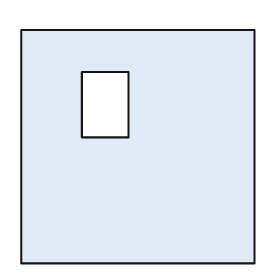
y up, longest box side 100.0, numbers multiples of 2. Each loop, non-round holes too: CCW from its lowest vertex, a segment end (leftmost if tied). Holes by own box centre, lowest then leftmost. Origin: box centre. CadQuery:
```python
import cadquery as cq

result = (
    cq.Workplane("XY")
    .moveTo(-50.0, -50.0)
    .lineTo(50.0, -50.0)
    .lineTo(50.0, 50.0)
    .lineTo(-50.0, 50.0)
    .close()
    .moveTo(-24.0, 4.0)
    .lineTo(-4.0, 4.0)
    .lineTo(-4.0, 32.0)
    .lineTo(-24.0, 32.0)
    .close()
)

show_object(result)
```